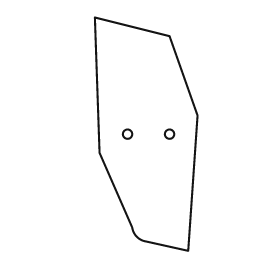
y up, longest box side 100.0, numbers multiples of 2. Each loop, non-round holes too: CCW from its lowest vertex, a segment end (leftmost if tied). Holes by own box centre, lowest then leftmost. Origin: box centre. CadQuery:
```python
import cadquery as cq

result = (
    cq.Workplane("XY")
    .moveTo(18.0, -50.0)
    .lineTo(22.0, 8.0)
    .lineTo(10.0, 42.0)
    .lineTo(-22.0, 50.0)
    .lineTo(-20.0, -8.0)
    .lineTo(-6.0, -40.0)
    .threePointArc((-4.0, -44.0), (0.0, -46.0))
    .close()
    .moveTo(-8.0, 0.0)
    .circle(2.0)
    .moveTo(10.0, 0.0)
    .circle(2.0)
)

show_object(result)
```